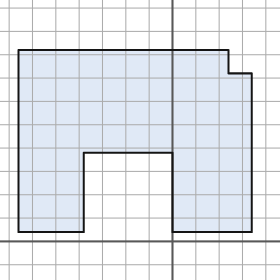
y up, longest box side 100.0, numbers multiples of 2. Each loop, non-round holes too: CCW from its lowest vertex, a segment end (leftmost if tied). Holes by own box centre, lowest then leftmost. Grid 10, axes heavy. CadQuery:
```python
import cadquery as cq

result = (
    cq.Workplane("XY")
    .moveTo(-66.0, 4.0)
    .lineTo(-38.0, 4.0)
    .lineTo(-38.0, 38.0)
    .lineTo(0.0, 38.0)
    .lineTo(0.0, 4.0)
    .lineTo(34.0, 4.0)
    .lineTo(34.0, 72.0)
    .lineTo(24.0, 72.0)
    .lineTo(24.0, 82.0)
    .lineTo(-66.0, 82.0)
    .close()
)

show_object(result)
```